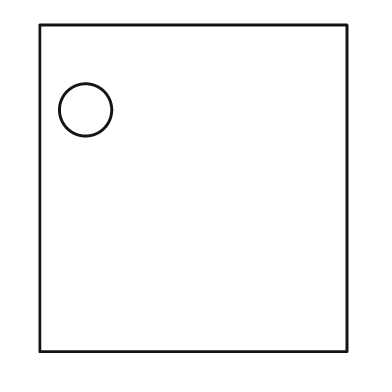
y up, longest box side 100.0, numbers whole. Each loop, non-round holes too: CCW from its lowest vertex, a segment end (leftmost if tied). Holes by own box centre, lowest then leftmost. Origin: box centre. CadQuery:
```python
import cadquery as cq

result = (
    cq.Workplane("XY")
    .moveTo(-47.0, -50.0)
    .lineTo(47.0, -50.0)
    .lineTo(47.0, 50.0)
    .lineTo(-47.0, 50.0)
    .close()
    .moveTo(-33.0, 24.0)
    .circle(8.0)
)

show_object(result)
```